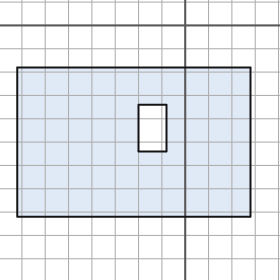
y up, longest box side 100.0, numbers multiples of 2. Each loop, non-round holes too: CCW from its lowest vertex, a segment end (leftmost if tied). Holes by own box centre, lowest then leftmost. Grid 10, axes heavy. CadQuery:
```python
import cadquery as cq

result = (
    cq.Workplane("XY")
    .moveTo(-72.0, -82.0)
    .lineTo(28.0, -82.0)
    .lineTo(28.0, -18.0)
    .lineTo(-72.0, -18.0)
    .close()
    .moveTo(-20.0, -54.0)
    .lineTo(-8.0, -54.0)
    .lineTo(-8.0, -34.0)
    .lineTo(-20.0, -34.0)
    .close()
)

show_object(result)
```